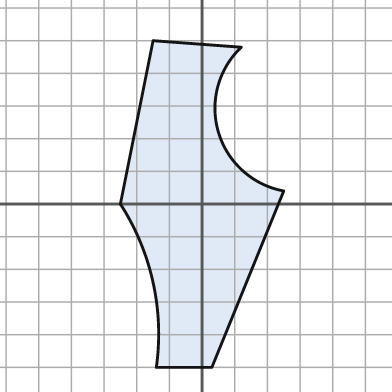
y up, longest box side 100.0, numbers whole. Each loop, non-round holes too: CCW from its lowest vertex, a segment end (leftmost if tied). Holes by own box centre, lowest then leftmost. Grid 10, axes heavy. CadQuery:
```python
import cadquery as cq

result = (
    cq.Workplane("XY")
    .moveTo(-14.0, -50.0)
    .lineTo(3.0, -50.0)
    .lineTo(25.0, 4.0)
    .threePointArc((5.0, 22.0), (12.0, 48.0))
    .lineTo(-15.0, 50.0)
    .lineTo(-25.0, 0.0)
    .threePointArc((-15.0, -24.0), (-14.0, -50.0))
    .close()
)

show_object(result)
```